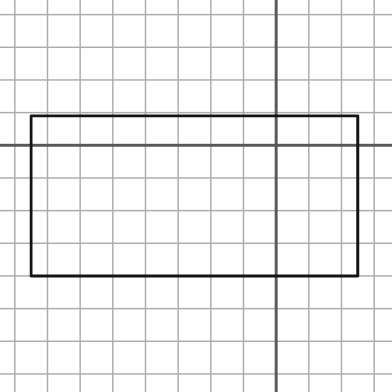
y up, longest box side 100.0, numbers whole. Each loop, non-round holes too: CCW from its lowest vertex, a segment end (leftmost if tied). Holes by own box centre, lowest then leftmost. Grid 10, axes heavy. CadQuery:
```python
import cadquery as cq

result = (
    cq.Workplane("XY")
    .moveTo(-75.0, -40.0)
    .lineTo(25.0, -40.0)
    .lineTo(25.0, 9.0)
    .lineTo(-75.0, 9.0)
    .close()
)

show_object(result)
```